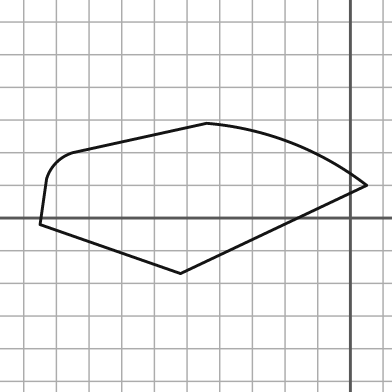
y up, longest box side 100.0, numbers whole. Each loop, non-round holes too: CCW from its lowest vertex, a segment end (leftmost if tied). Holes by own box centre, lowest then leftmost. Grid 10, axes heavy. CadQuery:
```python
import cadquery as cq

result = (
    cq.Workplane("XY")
    .moveTo(-52.0, -17.0)
    .lineTo(5.0, 10.0)
    .threePointArc((-18.0, 23.0), (-44.0, 29.0))
    .lineTo(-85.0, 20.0)
    .threePointArc((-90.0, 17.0), (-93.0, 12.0))
    .lineTo(-95.0, -2.0)
    .close()
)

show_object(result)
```